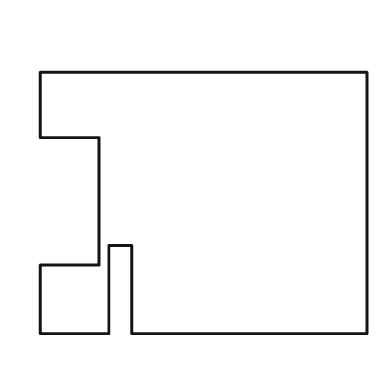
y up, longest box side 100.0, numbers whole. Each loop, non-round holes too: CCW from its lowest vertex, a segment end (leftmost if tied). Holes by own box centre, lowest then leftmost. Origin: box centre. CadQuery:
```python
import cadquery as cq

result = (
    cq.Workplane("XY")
    .moveTo(-50.0, -40.0)
    .lineTo(-29.0, -40.0)
    .lineTo(-29.0, -13.0)
    .lineTo(-22.0, -13.0)
    .lineTo(-22.0, -40.0)
    .lineTo(50.0, -40.0)
    .lineTo(50.0, 40.0)
    .lineTo(-50.0, 40.0)
    .lineTo(-50.0, 20.0)
    .lineTo(-32.0, 20.0)
    .lineTo(-32.0, -19.0)
    .lineTo(-50.0, -19.0)
    .close()
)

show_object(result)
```